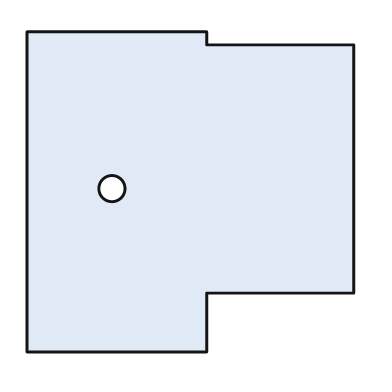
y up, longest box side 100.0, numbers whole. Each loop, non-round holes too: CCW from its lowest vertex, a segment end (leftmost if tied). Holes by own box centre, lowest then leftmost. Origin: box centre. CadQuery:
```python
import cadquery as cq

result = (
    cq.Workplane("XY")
    .moveTo(-50.0, -49.0)
    .lineTo(5.0, -49.0)
    .lineTo(5.0, -31.0)
    .lineTo(50.0, -31.0)
    .lineTo(50.0, 45.0)
    .lineTo(5.0, 45.0)
    .lineTo(5.0, 49.0)
    .lineTo(-50.0, 49.0)
    .close()
    .moveTo(-24.0, 1.0)
    .circle(4.0)
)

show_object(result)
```